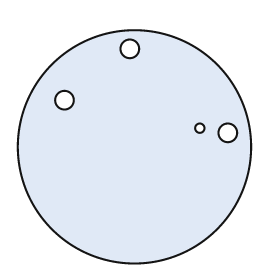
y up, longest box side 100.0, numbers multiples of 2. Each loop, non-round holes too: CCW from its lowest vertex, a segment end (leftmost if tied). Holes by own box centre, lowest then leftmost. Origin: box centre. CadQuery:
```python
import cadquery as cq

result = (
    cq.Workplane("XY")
    .moveTo(0.0, 0.0)
    .circle(50.0)
    .moveTo(40.0, 6.0)
    .circle(4.0)
    .moveTo(28.0, 8.0)
    .circle(2.0)
    .moveTo(-30.0, 20.0)
    .circle(4.0)
    .moveTo(-2.0, 42.0)
    .circle(4.0)
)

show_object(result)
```